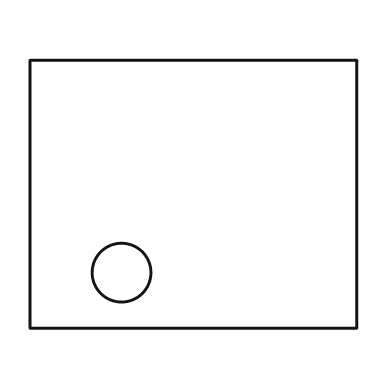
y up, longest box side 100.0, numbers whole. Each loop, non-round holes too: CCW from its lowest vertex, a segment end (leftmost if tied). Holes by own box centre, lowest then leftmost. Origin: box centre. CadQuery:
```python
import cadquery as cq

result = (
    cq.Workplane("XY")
    .moveTo(-50.0, -41.0)
    .lineTo(50.0, -41.0)
    .lineTo(50.0, 41.0)
    .lineTo(-50.0, 41.0)
    .close()
    .moveTo(-22.0, -24.0)
    .circle(9.0)
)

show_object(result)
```